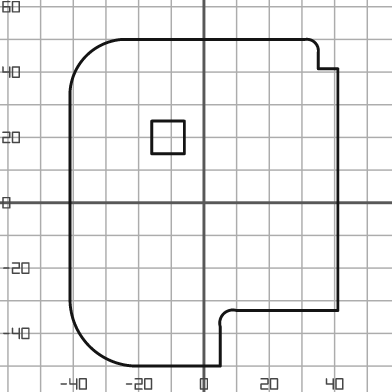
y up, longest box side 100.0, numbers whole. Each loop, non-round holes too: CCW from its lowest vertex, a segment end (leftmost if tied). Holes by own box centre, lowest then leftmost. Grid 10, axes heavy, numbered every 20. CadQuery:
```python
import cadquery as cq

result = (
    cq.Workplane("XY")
    .moveTo(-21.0, -50.0)
    .lineTo(5.0, -50.0)
    .lineTo(5.0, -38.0)
    .threePointArc((6.0, -34.0), (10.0, -33.0))
    .lineTo(41.0, -33.0)
    .lineTo(41.0, 41.0)
    .lineTo(35.0, 41.0)
    .lineTo(35.0, 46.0)
    .threePointArc((34.0, 49.0), (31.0, 50.0))
    .lineTo(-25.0, 50.0)
    .threePointArc((-36.0, 45.0), (-41.0, 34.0))
    .lineTo(-41.0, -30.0)
    .threePointArc((-35.0, -44.0), (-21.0, -50.0))
    .close()
    .moveTo(-16.0, 15.0)
    .lineTo(-6.0, 15.0)
    .lineTo(-6.0, 25.0)
    .lineTo(-16.0, 25.0)
    .close()
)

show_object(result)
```